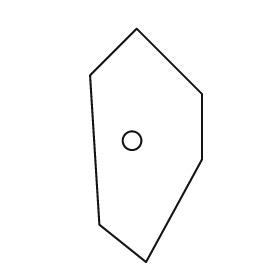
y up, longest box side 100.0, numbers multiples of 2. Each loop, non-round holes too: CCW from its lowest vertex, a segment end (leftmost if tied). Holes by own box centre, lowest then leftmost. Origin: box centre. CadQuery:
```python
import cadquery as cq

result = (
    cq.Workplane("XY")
    .moveTo(0.0, -50.0)
    .lineTo(24.0, -6.0)
    .lineTo(24.0, 22.0)
    .lineTo(-4.0, 50.0)
    .lineTo(-24.0, 30.0)
    .lineTo(-20.0, -34.0)
    .close()
    .moveTo(-6.0, 2.0)
    .circle(4.0)
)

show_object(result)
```